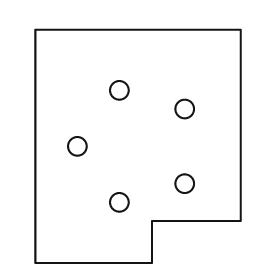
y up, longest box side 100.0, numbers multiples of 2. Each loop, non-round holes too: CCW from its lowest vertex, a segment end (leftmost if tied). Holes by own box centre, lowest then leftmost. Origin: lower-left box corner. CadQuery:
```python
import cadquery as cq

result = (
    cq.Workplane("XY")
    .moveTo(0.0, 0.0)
    .lineTo(50.0, 0.0)
    .lineTo(50.0, 18.0)
    .lineTo(88.0, 18.0)
    .lineTo(88.0, 100.0)
    .lineTo(0.0, 100.0)
    .close()
    .moveTo(36.0, 26.0)
    .circle(4.0)
    .moveTo(64.0, 34.0)
    .circle(4.0)
    .moveTo(18.0, 50.0)
    .circle(4.0)
    .moveTo(64.0, 66.0)
    .circle(4.0)
    .moveTo(36.0, 74.0)
    .circle(4.0)
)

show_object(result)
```